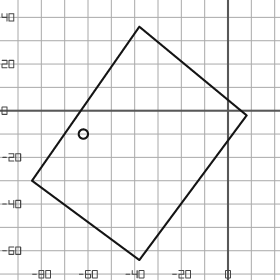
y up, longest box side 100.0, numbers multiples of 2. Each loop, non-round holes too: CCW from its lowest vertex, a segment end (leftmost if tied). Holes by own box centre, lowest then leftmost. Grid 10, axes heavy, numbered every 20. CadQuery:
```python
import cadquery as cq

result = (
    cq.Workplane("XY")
    .moveTo(-38.0, -64.0)
    .lineTo(8.0, -2.0)
    .lineTo(-38.0, 36.0)
    .lineTo(-84.0, -30.0)
    .close()
    .moveTo(-62.0, -10.0)
    .circle(2.0)
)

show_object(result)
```